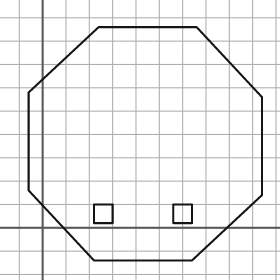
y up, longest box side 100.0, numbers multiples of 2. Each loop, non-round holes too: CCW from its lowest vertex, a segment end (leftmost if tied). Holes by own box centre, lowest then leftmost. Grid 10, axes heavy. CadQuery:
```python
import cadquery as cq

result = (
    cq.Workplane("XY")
    .moveTo(22.0, -14.0)
    .lineTo(64.0, -14.0)
    .lineTo(94.0, 14.0)
    .lineTo(94.0, 56.0)
    .lineTo(66.0, 86.0)
    .lineTo(24.0, 86.0)
    .lineTo(-6.0, 58.0)
    .lineTo(-6.0, 16.0)
    .close()
    .moveTo(22.0, 2.0)
    .lineTo(30.0, 2.0)
    .lineTo(30.0, 10.0)
    .lineTo(22.0, 10.0)
    .close()
    .moveTo(56.0, 2.0)
    .lineTo(64.0, 2.0)
    .lineTo(64.0, 10.0)
    .lineTo(56.0, 10.0)
    .close()
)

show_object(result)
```